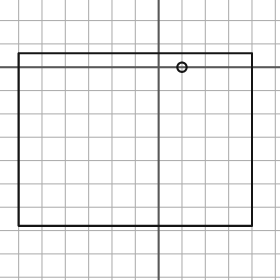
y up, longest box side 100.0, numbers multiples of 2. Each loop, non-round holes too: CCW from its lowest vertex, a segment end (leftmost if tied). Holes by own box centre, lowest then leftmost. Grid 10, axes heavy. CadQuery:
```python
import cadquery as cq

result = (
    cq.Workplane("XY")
    .moveTo(-60.0, -68.0)
    .lineTo(40.0, -68.0)
    .lineTo(40.0, 6.0)
    .lineTo(-60.0, 6.0)
    .close()
    .moveTo(10.0, 0.0)
    .circle(2.0)
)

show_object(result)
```